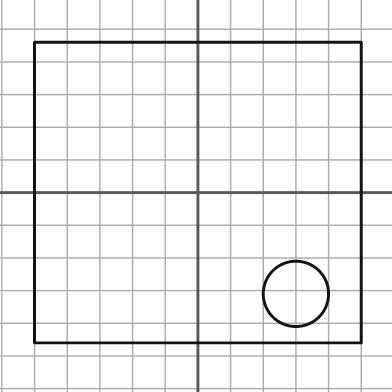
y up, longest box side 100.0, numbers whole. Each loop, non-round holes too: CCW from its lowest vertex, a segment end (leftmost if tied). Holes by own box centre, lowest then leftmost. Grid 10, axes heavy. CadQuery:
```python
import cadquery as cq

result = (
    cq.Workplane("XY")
    .moveTo(-50.0, -46.0)
    .lineTo(50.0, -46.0)
    .lineTo(50.0, 46.0)
    .lineTo(-50.0, 46.0)
    .close()
    .moveTo(30.0, -31.0)
    .circle(10.0)
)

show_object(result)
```